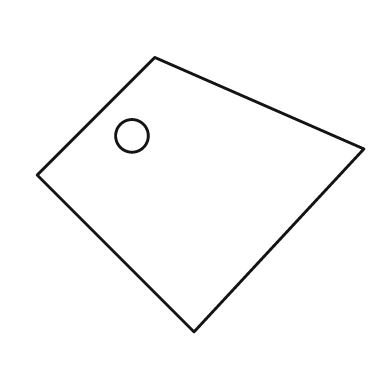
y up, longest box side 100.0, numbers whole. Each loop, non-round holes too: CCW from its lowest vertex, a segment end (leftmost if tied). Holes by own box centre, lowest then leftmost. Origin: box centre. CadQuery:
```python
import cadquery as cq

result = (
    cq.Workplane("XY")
    .moveTo(-2.0, -42.0)
    .lineTo(50.0, 14.0)
    .lineTo(-14.0, 42.0)
    .lineTo(-50.0, 6.0)
    .close()
    .moveTo(-21.0, 18.0)
    .circle(5.0)
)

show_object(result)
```